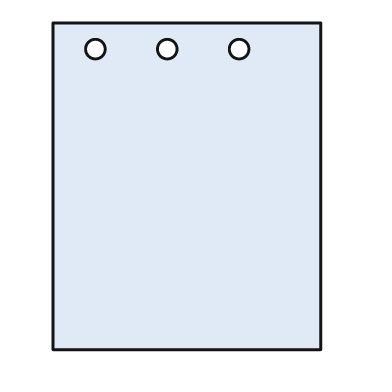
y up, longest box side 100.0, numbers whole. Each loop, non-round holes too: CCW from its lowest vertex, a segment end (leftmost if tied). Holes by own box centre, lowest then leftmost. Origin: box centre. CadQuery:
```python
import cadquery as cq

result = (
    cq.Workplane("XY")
    .moveTo(-41.0, -50.0)
    .lineTo(41.0, -50.0)
    .lineTo(41.0, 50.0)
    .lineTo(-41.0, 50.0)
    .close()
    .moveTo(-28.0, 42.0)
    .circle(3.0)
    .moveTo(-6.0, 42.0)
    .circle(3.0)
    .moveTo(16.0, 42.0)
    .circle(3.0)
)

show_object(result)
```